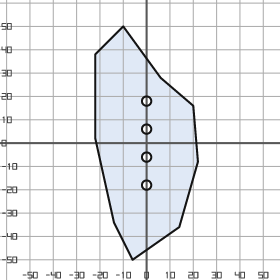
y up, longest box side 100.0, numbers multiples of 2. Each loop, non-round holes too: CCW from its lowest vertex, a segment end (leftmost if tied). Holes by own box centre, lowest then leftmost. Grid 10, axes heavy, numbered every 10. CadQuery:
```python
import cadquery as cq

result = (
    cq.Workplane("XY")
    .moveTo(-6.0, -50.0)
    .lineTo(14.0, -36.0)
    .lineTo(22.0, -8.0)
    .lineTo(20.0, 16.0)
    .lineTo(6.0, 28.0)
    .lineTo(-10.0, 50.0)
    .lineTo(-22.0, 38.0)
    .lineTo(-22.0, 2.0)
    .lineTo(-14.0, -34.0)
    .close()
    .moveTo(0.0, -18.0)
    .circle(2.0)
    .moveTo(0.0, -6.0)
    .circle(2.0)
    .moveTo(0.0, 6.0)
    .circle(2.0)
    .moveTo(0.0, 18.0)
    .circle(2.0)
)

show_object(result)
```